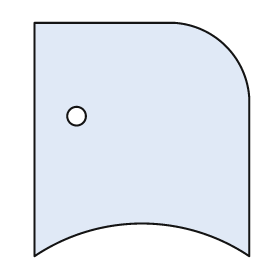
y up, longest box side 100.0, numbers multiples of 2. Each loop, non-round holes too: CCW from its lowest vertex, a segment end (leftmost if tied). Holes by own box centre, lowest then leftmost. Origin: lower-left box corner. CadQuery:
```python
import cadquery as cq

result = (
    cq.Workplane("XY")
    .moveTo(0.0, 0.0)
    .threePointArc((46.0, 14.0), (92.0, 0.0))
    .lineTo(92.0, 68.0)
    .threePointArc((82.0, 90.0), (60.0, 100.0))
    .lineTo(0.0, 100.0)
    .close()
    .moveTo(18.0, 60.0)
    .circle(4.0)
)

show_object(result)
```